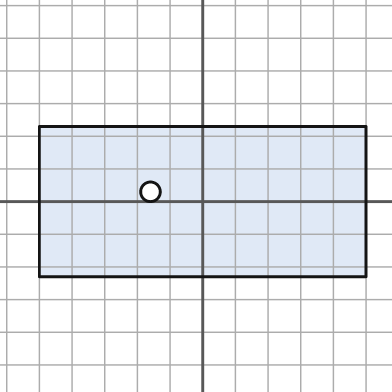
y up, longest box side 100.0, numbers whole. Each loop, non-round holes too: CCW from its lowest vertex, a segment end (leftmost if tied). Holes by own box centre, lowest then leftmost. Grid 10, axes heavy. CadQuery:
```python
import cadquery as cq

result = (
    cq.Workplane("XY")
    .moveTo(-50.0, -23.0)
    .lineTo(50.0, -23.0)
    .lineTo(50.0, 23.0)
    .lineTo(-50.0, 23.0)
    .close()
    .moveTo(-16.0, 3.0)
    .circle(3.0)
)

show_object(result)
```